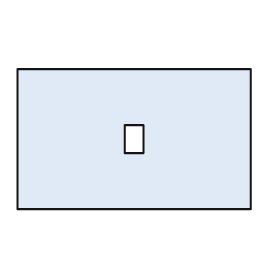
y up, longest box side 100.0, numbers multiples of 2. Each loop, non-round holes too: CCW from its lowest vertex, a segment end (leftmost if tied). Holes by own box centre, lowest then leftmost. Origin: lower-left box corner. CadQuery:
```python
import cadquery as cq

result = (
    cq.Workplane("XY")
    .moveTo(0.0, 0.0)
    .lineTo(100.0, 0.0)
    .lineTo(100.0, 60.0)
    .lineTo(0.0, 60.0)
    .close()
    .moveTo(46.0, 24.0)
    .lineTo(54.0, 24.0)
    .lineTo(54.0, 36.0)
    .lineTo(46.0, 36.0)
    .close()
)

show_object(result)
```